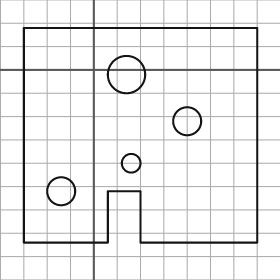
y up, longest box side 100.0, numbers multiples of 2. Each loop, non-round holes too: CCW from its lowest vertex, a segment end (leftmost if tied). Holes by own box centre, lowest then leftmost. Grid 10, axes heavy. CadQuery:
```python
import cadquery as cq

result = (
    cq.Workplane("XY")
    .moveTo(-30.0, -74.0)
    .lineTo(6.0, -74.0)
    .lineTo(6.0, -52.0)
    .lineTo(20.0, -52.0)
    .lineTo(20.0, -74.0)
    .lineTo(70.0, -74.0)
    .lineTo(70.0, 18.0)
    .lineTo(-30.0, 18.0)
    .close()
    .moveTo(-14.0, -52.0)
    .circle(6.0)
    .moveTo(16.0, -40.0)
    .circle(4.0)
    .moveTo(40.0, -22.0)
    .circle(6.0)
    .moveTo(14.0, -2.0)
    .circle(8.0)
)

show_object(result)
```